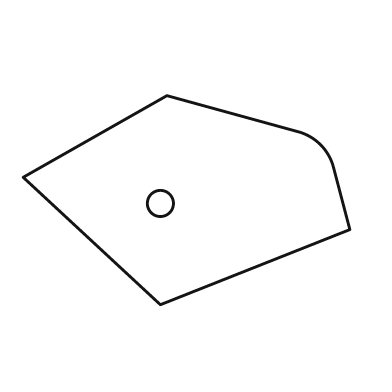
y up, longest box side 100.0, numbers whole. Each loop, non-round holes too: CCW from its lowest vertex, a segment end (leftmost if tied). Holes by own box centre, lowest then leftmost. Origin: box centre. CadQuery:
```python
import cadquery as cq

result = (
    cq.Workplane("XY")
    .moveTo(-8.0, -32.0)
    .lineTo(50.0, -9.0)
    .lineTo(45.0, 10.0)
    .threePointArc((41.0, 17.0), (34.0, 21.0))
    .lineTo(-6.0, 32.0)
    .lineTo(-50.0, 7.0)
    .close()
    .moveTo(-8.0, -1.0)
    .circle(4.0)
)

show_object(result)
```